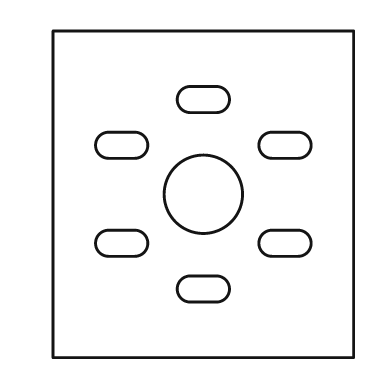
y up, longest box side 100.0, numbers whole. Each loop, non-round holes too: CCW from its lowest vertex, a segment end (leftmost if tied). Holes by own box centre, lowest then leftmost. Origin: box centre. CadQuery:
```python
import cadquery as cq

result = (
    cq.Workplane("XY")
    .moveTo(-46.0, -50.0)
    .lineTo(46.0, -50.0)
    .lineTo(46.0, 50.0)
    .lineTo(-46.0, 50.0)
    .close()
    .moveTo(-4.0, -33.0)
    .lineTo(4.0, -33.0)
    .threePointArc((8.0, -29.0), (4.0, -25.0))
    .lineTo(-4.0, -25.0)
    .threePointArc((-8.0, -29.0), (-4.0, -33.0))
    .close()
    .moveTo(-29.0, -19.0)
    .lineTo(-21.0, -19.0)
    .threePointArc((-17.0, -15.0), (-21.0, -11.0))
    .lineTo(-29.0, -11.0)
    .threePointArc((-33.0, -15.0), (-29.0, -19.0))
    .close()
    .moveTo(21.0, -19.0)
    .lineTo(29.0, -19.0)
    .threePointArc((33.0, -15.0), (29.0, -11.0))
    .lineTo(21.0, -11.0)
    .threePointArc((17.0, -15.0), (21.0, -19.0))
    .close()
    .moveTo(0.0, 0.0)
    .circle(12.0)
    .moveTo(-29.0, 11.0)
    .lineTo(-21.0, 11.0)
    .threePointArc((-17.0, 15.0), (-21.0, 19.0))
    .lineTo(-29.0, 19.0)
    .threePointArc((-33.0, 15.0), (-29.0, 11.0))
    .close()
    .moveTo(21.0, 11.0)
    .lineTo(29.0, 11.0)
    .threePointArc((33.0, 15.0), (29.0, 19.0))
    .lineTo(21.0, 19.0)
    .threePointArc((17.0, 15.0), (21.0, 11.0))
    .close()
    .moveTo(-4.0, 25.0)
    .lineTo(4.0, 25.0)
    .threePointArc((8.0, 29.0), (4.0, 33.0))
    .lineTo(-4.0, 33.0)
    .threePointArc((-8.0, 29.0), (-4.0, 25.0))
    .close()
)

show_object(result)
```